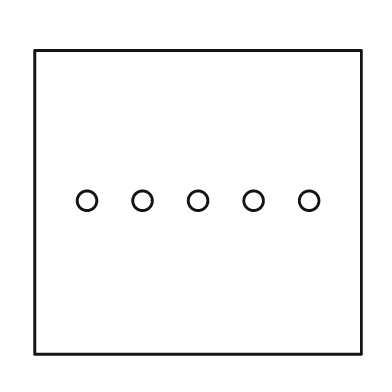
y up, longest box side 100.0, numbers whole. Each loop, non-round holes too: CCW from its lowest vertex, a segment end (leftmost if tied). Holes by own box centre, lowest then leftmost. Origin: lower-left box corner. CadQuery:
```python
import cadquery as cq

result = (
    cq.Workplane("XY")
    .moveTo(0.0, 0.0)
    .lineTo(100.0, 0.0)
    .lineTo(100.0, 93.0)
    .lineTo(0.0, 93.0)
    .close()
    .moveTo(16.0, 47.0)
    .circle(3.0)
    .moveTo(33.0, 47.0)
    .circle(3.0)
    .moveTo(50.0, 47.0)
    .circle(3.0)
    .moveTo(67.0, 47.0)
    .circle(3.0)
    .moveTo(84.0, 47.0)
    .circle(3.0)
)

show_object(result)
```